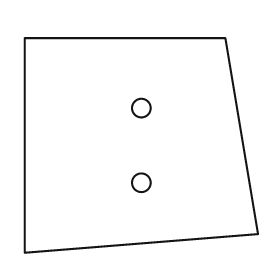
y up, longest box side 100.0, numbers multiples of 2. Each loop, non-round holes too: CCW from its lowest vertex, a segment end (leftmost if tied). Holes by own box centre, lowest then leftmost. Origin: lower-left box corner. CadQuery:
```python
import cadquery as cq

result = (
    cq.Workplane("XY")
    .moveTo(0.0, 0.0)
    .lineTo(100.0, 8.0)
    .lineTo(86.0, 92.0)
    .lineTo(0.0, 92.0)
    .close()
    .moveTo(50.0, 30.0)
    .circle(4.0)
    .moveTo(50.0, 62.0)
    .circle(4.0)
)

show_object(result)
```